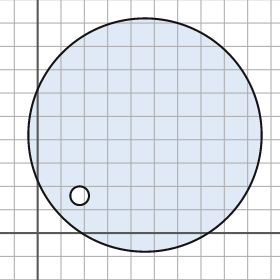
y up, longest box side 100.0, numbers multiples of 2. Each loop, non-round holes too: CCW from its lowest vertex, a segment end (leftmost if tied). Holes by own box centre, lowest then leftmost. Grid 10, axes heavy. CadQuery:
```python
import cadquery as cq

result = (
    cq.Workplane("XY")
    .moveTo(46.0, 42.0)
    .circle(50.0)
    .moveTo(18.0, 16.0)
    .circle(4.0)
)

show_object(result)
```